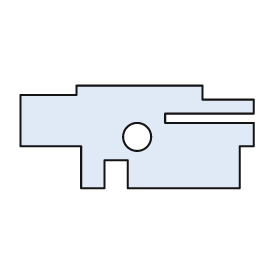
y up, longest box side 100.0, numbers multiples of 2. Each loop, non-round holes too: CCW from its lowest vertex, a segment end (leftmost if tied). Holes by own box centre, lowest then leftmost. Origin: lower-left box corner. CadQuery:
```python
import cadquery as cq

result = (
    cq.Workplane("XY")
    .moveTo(26.0, 0.0)
    .lineTo(36.0, 0.0)
    .lineTo(36.0, 12.0)
    .lineTo(46.0, 12.0)
    .lineTo(46.0, 0.0)
    .lineTo(94.0, 0.0)
    .lineTo(94.0, 18.0)
    .lineTo(100.0, 18.0)
    .lineTo(100.0, 28.0)
    .lineTo(62.0, 28.0)
    .lineTo(62.0, 32.0)
    .lineTo(100.0, 32.0)
    .lineTo(100.0, 38.0)
    .lineTo(78.0, 38.0)
    .lineTo(78.0, 44.0)
    .lineTo(24.0, 44.0)
    .lineTo(24.0, 40.0)
    .lineTo(0.0, 40.0)
    .lineTo(0.0, 18.0)
    .lineTo(26.0, 18.0)
    .close()
    .moveTo(50.0, 22.0)
    .circle(6.0)
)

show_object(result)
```